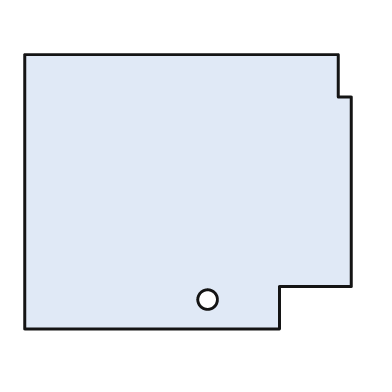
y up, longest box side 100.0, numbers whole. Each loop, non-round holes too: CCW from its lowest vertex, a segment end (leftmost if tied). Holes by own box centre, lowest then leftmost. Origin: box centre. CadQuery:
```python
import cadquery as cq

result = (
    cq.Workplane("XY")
    .moveTo(-50.0, -42.0)
    .lineTo(28.0, -42.0)
    .lineTo(28.0, -29.0)
    .lineTo(50.0, -29.0)
    .lineTo(50.0, 29.0)
    .lineTo(46.0, 29.0)
    .lineTo(46.0, 42.0)
    .lineTo(-50.0, 42.0)
    .close()
    .moveTo(6.0, -33.0)
    .circle(3.0)
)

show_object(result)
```